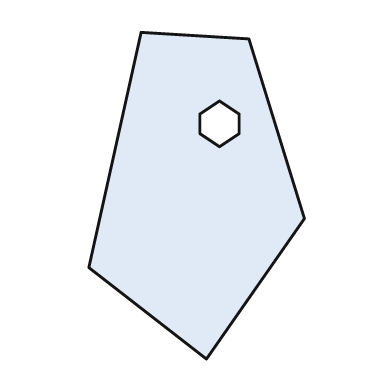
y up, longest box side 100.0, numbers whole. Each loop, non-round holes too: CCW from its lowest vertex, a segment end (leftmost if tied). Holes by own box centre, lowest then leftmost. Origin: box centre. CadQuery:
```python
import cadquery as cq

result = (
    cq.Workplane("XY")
    .moveTo(3.0, -50.0)
    .lineTo(33.0, -7.0)
    .lineTo(16.0, 48.0)
    .lineTo(-17.0, 50.0)
    .lineTo(-33.0, -22.0)
    .close()
    .moveTo(7.0, 15.0)
    .lineTo(13.0, 19.0)
    .lineTo(13.0, 25.0)
    .lineTo(7.0, 29.0)
    .lineTo(1.0, 25.0)
    .lineTo(1.0, 19.0)
    .close()
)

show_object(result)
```